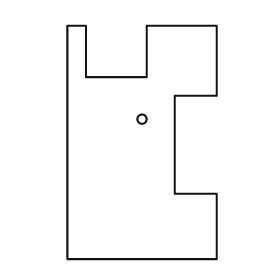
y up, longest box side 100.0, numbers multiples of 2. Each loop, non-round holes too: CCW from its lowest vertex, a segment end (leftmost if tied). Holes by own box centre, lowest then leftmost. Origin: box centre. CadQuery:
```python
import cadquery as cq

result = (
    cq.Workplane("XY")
    .moveTo(-32.0, -50.0)
    .lineTo(32.0, -50.0)
    .lineTo(32.0, -22.0)
    .lineTo(14.0, -22.0)
    .lineTo(14.0, 20.0)
    .lineTo(32.0, 20.0)
    .lineTo(32.0, 50.0)
    .lineTo(2.0, 50.0)
    .lineTo(2.0, 28.0)
    .lineTo(-24.0, 28.0)
    .lineTo(-24.0, 50.0)
    .lineTo(-32.0, 50.0)
    .close()
    .moveTo(0.0, 10.0)
    .circle(2.0)
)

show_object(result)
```